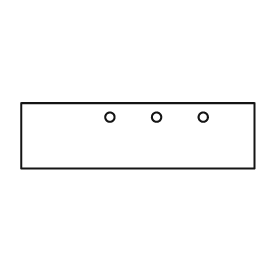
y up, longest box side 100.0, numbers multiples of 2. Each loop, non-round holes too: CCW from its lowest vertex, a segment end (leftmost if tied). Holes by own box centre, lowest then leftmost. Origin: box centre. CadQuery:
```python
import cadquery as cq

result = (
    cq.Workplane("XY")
    .moveTo(-50.0, -14.0)
    .lineTo(50.0, -14.0)
    .lineTo(50.0, 14.0)
    .lineTo(-50.0, 14.0)
    .close()
    .moveTo(-12.0, 8.0)
    .circle(2.0)
    .moveTo(8.0, 8.0)
    .circle(2.0)
    .moveTo(28.0, 8.0)
    .circle(2.0)
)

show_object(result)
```